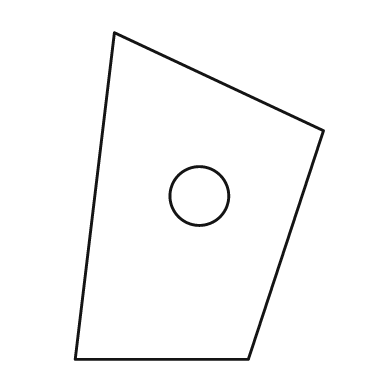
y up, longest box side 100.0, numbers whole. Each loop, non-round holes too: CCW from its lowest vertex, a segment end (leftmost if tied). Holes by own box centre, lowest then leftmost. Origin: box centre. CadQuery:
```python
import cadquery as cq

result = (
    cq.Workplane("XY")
    .moveTo(-38.0, -50.0)
    .lineTo(15.0, -50.0)
    .lineTo(38.0, 20.0)
    .lineTo(-26.0, 50.0)
    .close()
    .moveTo(0.0, 0.0)
    .circle(9.0)
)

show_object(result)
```